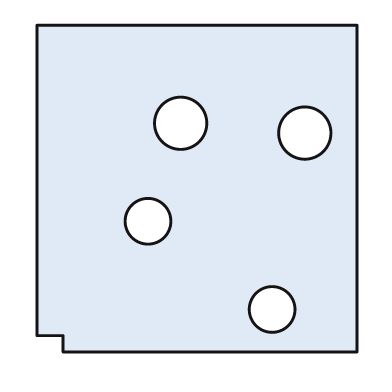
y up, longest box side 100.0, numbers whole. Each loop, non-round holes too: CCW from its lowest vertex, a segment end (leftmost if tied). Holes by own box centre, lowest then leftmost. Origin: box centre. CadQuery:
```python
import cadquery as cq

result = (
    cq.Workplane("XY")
    .moveTo(-41.0, -50.0)
    .lineTo(49.0, -50.0)
    .lineTo(49.0, 50.0)
    .lineTo(-49.0, 50.0)
    .lineTo(-49.0, -45.0)
    .lineTo(-41.0, -45.0)
    .close()
    .moveTo(23.0, -37.0)
    .circle(7.0)
    .moveTo(-15.0, -10.0)
    .circle(7.0)
    .moveTo(33.0, 17.0)
    .circle(8.0)
    .moveTo(-5.0, 20.0)
    .circle(8.0)
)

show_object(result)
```